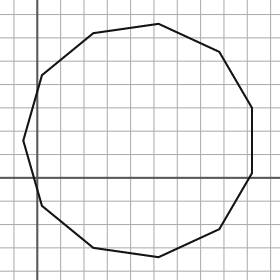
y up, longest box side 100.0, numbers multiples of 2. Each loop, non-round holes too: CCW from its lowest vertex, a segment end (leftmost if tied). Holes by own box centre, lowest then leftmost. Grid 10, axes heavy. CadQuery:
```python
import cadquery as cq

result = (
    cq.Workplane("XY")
    .moveTo(52.0, -34.0)
    .lineTo(78.0, -22.0)
    .lineTo(92.0, 2.0)
    .lineTo(92.0, 30.0)
    .lineTo(78.0, 54.0)
    .lineTo(52.0, 66.0)
    .lineTo(24.0, 62.0)
    .lineTo(2.0, 44.0)
    .lineTo(-6.0, 16.0)
    .lineTo(2.0, -12.0)
    .lineTo(24.0, -30.0)
    .close()
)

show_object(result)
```